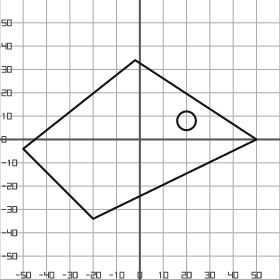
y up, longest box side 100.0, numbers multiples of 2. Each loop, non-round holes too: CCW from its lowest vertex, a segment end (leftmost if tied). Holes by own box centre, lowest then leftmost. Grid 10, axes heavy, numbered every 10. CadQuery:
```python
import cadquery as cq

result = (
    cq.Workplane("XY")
    .moveTo(-20.0, -34.0)
    .lineTo(50.0, 0.0)
    .lineTo(-2.0, 34.0)
    .lineTo(-50.0, -4.0)
    .close()
    .moveTo(20.0, 8.0)
    .circle(4.0)
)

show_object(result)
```